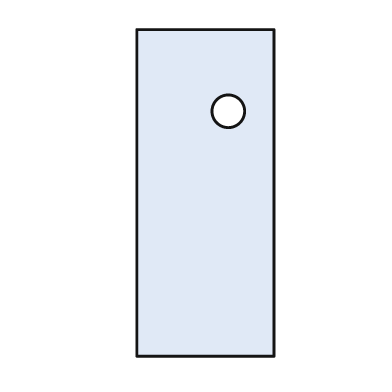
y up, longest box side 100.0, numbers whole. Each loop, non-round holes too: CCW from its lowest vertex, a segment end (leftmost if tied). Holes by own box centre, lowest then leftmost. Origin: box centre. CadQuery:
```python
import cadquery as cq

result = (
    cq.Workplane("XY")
    .moveTo(-21.0, -50.0)
    .lineTo(21.0, -50.0)
    .lineTo(21.0, 50.0)
    .lineTo(-21.0, 50.0)
    .close()
    .moveTo(7.0, 25.0)
    .circle(5.0)
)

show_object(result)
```